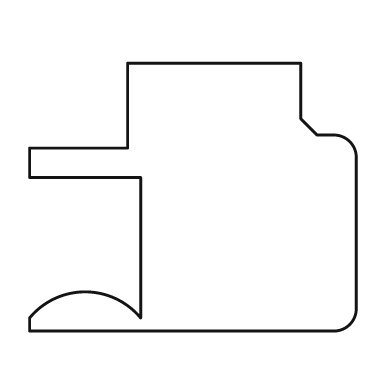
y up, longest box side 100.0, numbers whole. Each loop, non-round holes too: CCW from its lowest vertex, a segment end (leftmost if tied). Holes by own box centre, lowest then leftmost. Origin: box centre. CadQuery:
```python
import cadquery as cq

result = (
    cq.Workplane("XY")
    .moveTo(-50.0, -41.0)
    .lineTo(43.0, -41.0)
    .threePointArc((48.0, -39.0), (50.0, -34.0))
    .lineTo(50.0, 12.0)
    .threePointArc((48.0, 17.0), (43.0, 19.0))
    .lineTo(38.0, 19.0)
    .lineTo(33.0, 24.0)
    .lineTo(33.0, 41.0)
    .lineTo(-20.0, 41.0)
    .lineTo(-20.0, 15.0)
    .lineTo(-50.0, 15.0)
    .lineTo(-50.0, 6.0)
    .lineTo(-16.0, 6.0)
    .lineTo(-16.0, -37.0)
    .threePointArc((-33.0, -29.0), (-50.0, -37.0))
    .close()
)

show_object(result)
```